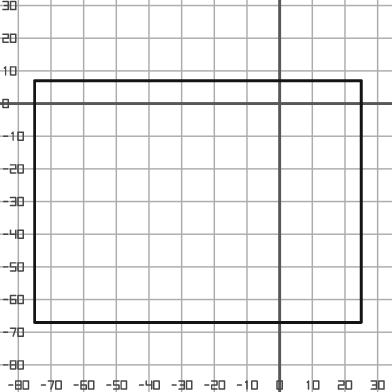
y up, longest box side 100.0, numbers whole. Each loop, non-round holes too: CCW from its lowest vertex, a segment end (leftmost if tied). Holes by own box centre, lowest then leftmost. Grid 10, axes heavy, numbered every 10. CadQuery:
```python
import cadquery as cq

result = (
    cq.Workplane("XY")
    .moveTo(-75.0, -67.0)
    .lineTo(25.0, -67.0)
    .lineTo(25.0, 7.0)
    .lineTo(-75.0, 7.0)
    .close()
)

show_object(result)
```